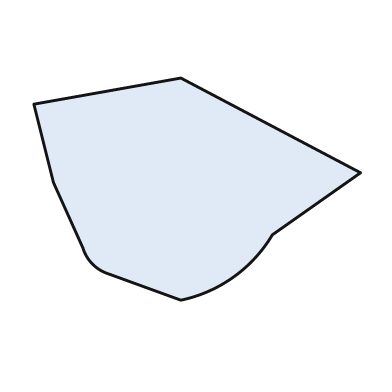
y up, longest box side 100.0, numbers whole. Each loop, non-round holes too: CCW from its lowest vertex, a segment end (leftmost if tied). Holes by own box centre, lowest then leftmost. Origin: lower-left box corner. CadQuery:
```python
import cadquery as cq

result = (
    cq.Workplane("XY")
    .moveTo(45.0, 0.0)
    .threePointArc((61.0, 7.0), (73.0, 20.0))
    .lineTo(100.0, 39.0)
    .lineTo(45.0, 68.0)
    .lineTo(0.0, 60.0)
    .lineTo(6.0, 36.0)
    .lineTo(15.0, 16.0)
    .threePointArc((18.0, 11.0), (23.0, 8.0))
    .close()
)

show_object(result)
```